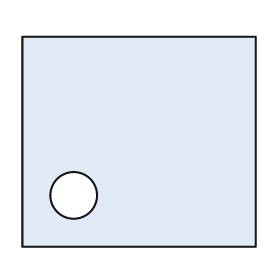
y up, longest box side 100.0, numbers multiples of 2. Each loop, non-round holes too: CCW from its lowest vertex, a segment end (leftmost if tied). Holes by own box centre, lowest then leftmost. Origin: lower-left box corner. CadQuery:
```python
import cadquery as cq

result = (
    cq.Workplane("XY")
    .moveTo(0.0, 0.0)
    .lineTo(100.0, 0.0)
    .lineTo(100.0, 90.0)
    .lineTo(0.0, 90.0)
    .close()
    .moveTo(22.0, 22.0)
    .circle(10.0)
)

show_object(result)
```